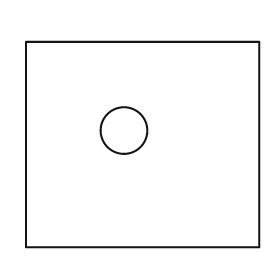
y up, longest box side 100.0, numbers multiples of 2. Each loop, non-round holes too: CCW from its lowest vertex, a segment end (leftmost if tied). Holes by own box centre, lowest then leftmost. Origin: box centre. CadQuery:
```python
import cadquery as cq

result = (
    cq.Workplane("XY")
    .moveTo(-50.0, -44.0)
    .lineTo(50.0, -44.0)
    .lineTo(50.0, 44.0)
    .lineTo(-50.0, 44.0)
    .close()
    .moveTo(-8.0, 6.0)
    .circle(10.0)
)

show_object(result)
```